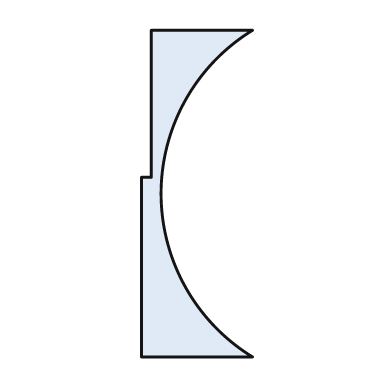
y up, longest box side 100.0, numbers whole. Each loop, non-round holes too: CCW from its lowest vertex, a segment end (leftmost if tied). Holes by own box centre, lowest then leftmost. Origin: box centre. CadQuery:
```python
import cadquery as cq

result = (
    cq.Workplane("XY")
    .moveTo(-17.0, -50.0)
    .lineTo(17.0, -50.0)
    .threePointArc((-11.0, 0.0), (17.0, 50.0))
    .lineTo(-14.0, 50.0)
    .lineTo(-14.0, 5.0)
    .lineTo(-17.0, 5.0)
    .close()
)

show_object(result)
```